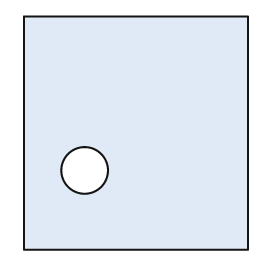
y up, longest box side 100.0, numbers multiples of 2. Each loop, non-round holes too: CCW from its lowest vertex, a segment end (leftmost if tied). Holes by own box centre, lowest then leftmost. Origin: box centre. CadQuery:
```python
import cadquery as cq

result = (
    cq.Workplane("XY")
    .moveTo(-48.0, -50.0)
    .lineTo(48.0, -50.0)
    .lineTo(48.0, 50.0)
    .lineTo(-48.0, 50.0)
    .close()
    .moveTo(-22.0, -16.0)
    .circle(10.0)
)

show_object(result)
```